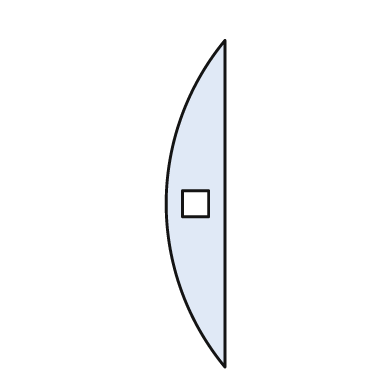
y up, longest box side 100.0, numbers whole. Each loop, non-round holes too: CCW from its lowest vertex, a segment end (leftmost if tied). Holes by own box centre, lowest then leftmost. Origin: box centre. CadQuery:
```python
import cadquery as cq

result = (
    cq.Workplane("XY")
    .moveTo(9.0, -50.0)
    .lineTo(9.0, 50.0)
    .threePointArc((-9.0, 0.0), (9.0, -50.0))
    .close()
    .moveTo(-4.0, -4.0)
    .lineTo(4.0, -4.0)
    .lineTo(4.0, 4.0)
    .lineTo(-4.0, 4.0)
    .close()
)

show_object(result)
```